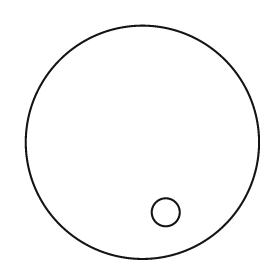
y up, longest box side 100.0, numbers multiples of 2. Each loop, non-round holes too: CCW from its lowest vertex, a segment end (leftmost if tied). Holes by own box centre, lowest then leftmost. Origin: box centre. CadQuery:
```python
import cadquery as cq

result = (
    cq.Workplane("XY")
    .moveTo(0.0, 0.0)
    .circle(50.0)
    .moveTo(10.0, -30.0)
    .circle(6.0)
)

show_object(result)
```